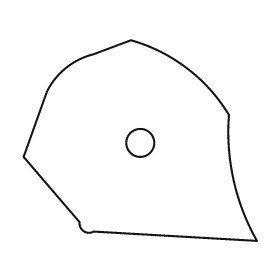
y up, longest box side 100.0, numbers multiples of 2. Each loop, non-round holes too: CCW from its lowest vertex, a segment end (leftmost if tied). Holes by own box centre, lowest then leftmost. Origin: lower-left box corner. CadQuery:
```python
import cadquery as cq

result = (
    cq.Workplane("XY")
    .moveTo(100.0, 0.0)
    .threePointArc((90.0, 26.0), (88.0, 54.0))
    .threePointArc((70.0, 74.0), (46.0, 86.0))
    .lineTo(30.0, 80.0)
    .threePointArc((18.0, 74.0), (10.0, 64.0))
    .lineTo(0.0, 36.0)
    .lineTo(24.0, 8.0)
    .threePointArc((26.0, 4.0), (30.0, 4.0))
    .close()
    .moveTo(50.0, 42.0)
    .circle(6.0)
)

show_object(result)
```